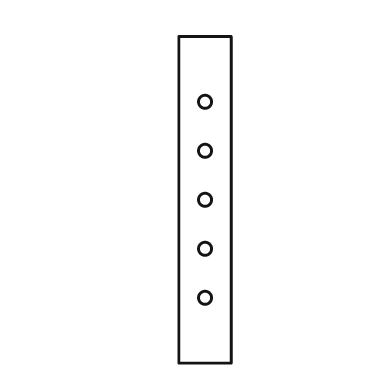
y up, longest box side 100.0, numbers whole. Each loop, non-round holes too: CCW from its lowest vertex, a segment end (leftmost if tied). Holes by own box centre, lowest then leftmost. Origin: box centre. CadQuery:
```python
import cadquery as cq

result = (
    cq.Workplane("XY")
    .moveTo(-8.0, -50.0)
    .lineTo(8.0, -50.0)
    .lineTo(8.0, 50.0)
    .lineTo(-8.0, 50.0)
    .close()
    .moveTo(0.0, -30.0)
    .circle(2.0)
    .moveTo(0.0, -15.0)
    .circle(2.0)
    .moveTo(0.0, 0.0)
    .circle(2.0)
    .moveTo(0.0, 15.0)
    .circle(2.0)
    .moveTo(0.0, 30.0)
    .circle(2.0)
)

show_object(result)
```